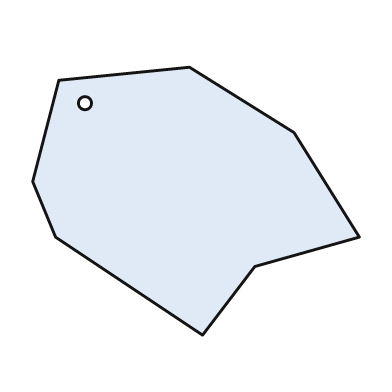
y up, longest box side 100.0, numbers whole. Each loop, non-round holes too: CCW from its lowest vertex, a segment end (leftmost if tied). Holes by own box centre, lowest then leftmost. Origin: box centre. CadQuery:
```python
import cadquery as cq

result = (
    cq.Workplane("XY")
    .moveTo(2.0, -41.0)
    .lineTo(18.0, -20.0)
    .lineTo(50.0, -11.0)
    .lineTo(30.0, 21.0)
    .lineTo(-2.0, 41.0)
    .lineTo(-42.0, 37.0)
    .lineTo(-50.0, 6.0)
    .lineTo(-43.0, -11.0)
    .close()
    .moveTo(-34.0, 30.0)
    .circle(2.0)
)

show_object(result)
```